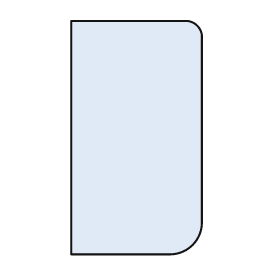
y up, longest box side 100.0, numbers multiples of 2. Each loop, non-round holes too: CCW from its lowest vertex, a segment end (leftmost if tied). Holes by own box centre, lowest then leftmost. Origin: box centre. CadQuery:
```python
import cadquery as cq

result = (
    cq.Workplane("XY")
    .moveTo(-28.0, -50.0)
    .lineTo(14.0, -50.0)
    .threePointArc((24.0, -46.0), (28.0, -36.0))
    .lineTo(28.0, 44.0)
    .threePointArc((26.0, 48.0), (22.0, 50.0))
    .lineTo(-28.0, 50.0)
    .close()
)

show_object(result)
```